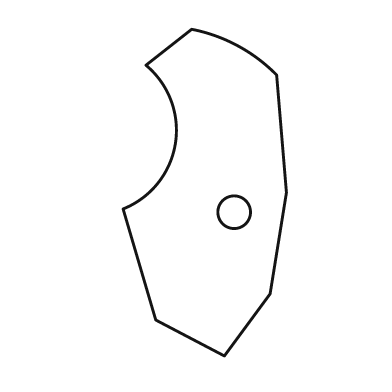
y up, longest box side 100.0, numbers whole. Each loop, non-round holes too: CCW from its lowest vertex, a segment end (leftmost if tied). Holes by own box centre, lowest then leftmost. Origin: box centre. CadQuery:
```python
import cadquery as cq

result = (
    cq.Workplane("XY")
    .moveTo(6.0, -50.0)
    .lineTo(20.0, -31.0)
    .lineTo(25.0, 0.0)
    .lineTo(22.0, 36.0)
    .threePointArc((10.0, 45.0), (-4.0, 50.0))
    .lineTo(-18.0, 39.0)
    .threePointArc((-9.0, 15.0), (-25.0, -5.0))
    .lineTo(-15.0, -39.0)
    .close()
    .moveTo(9.0, -6.0)
    .circle(5.0)
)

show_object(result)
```